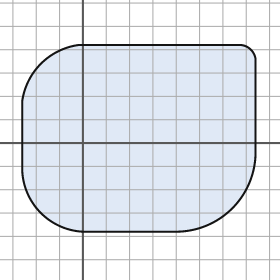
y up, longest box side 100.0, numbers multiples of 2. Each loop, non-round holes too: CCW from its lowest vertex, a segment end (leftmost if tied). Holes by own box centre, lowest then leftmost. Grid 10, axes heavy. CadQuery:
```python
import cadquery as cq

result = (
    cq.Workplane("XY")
    .moveTo(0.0, -38.0)
    .lineTo(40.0, -38.0)
    .threePointArc((64.0, -28.0), (74.0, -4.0))
    .lineTo(74.0, 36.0)
    .threePointArc((72.0, 40.0), (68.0, 42.0))
    .lineTo(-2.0, 42.0)
    .threePointArc((-18.0, 34.0), (-26.0, 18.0))
    .lineTo(-26.0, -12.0)
    .threePointArc((-18.0, -30.0), (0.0, -38.0))
    .close()
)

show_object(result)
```